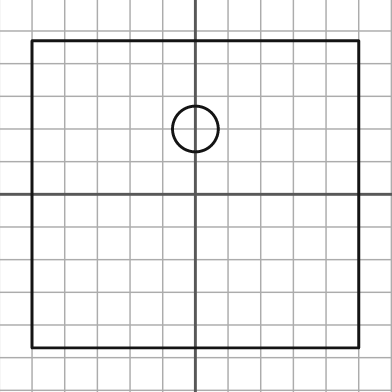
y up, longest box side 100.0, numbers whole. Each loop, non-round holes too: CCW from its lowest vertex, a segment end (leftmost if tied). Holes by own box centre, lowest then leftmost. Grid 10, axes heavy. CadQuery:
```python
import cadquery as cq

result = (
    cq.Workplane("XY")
    .moveTo(-50.0, -47.0)
    .lineTo(50.0, -47.0)
    .lineTo(50.0, 47.0)
    .lineTo(-50.0, 47.0)
    .close()
    .moveTo(0.0, 20.0)
    .circle(7.0)
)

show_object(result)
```